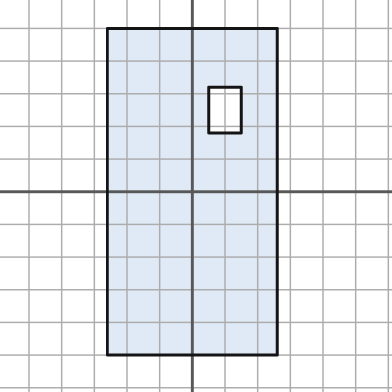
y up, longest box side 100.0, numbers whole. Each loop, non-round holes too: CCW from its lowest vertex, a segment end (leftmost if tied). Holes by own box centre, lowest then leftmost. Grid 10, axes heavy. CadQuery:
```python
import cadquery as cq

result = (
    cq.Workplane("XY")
    .moveTo(-26.0, -50.0)
    .lineTo(26.0, -50.0)
    .lineTo(26.0, 50.0)
    .lineTo(-26.0, 50.0)
    .close()
    .moveTo(5.0, 18.0)
    .lineTo(15.0, 18.0)
    .lineTo(15.0, 32.0)
    .lineTo(5.0, 32.0)
    .close()
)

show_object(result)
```